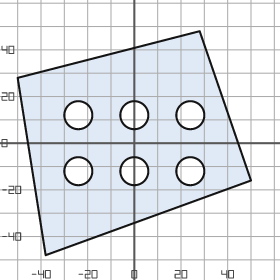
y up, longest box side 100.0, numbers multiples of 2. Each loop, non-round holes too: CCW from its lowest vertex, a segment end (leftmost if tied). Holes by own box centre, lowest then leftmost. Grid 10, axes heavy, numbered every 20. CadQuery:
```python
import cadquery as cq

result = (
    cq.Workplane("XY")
    .moveTo(-38.0, -48.0)
    .lineTo(50.0, -16.0)
    .lineTo(28.0, 48.0)
    .lineTo(-50.0, 28.0)
    .close()
    .moveTo(-24.0, -12.0)
    .circle(6.0)
    .moveTo(0.0, -12.0)
    .circle(6.0)
    .moveTo(24.0, -12.0)
    .circle(6.0)
    .moveTo(-24.0, 12.0)
    .circle(6.0)
    .moveTo(0.0, 12.0)
    .circle(6.0)
    .moveTo(24.0, 12.0)
    .circle(6.0)
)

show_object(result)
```